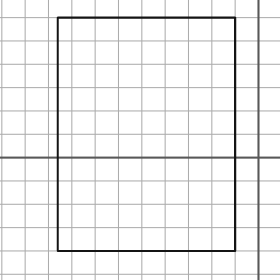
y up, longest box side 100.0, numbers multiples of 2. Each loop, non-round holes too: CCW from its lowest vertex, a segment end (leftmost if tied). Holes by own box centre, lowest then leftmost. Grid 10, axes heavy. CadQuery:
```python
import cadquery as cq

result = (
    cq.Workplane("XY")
    .moveTo(-86.0, -40.0)
    .lineTo(-10.0, -40.0)
    .lineTo(-10.0, 60.0)
    .lineTo(-86.0, 60.0)
    .close()
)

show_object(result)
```